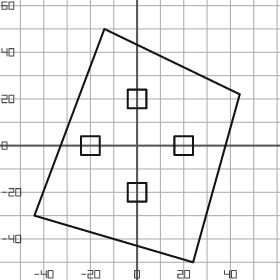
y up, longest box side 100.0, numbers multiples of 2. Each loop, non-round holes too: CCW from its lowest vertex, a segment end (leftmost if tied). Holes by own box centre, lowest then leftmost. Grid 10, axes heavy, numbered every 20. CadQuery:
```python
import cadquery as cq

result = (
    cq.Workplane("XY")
    .moveTo(24.0, -50.0)
    .lineTo(44.0, 22.0)
    .lineTo(-14.0, 50.0)
    .lineTo(-44.0, -30.0)
    .close()
    .moveTo(-4.0, -24.0)
    .lineTo(4.0, -24.0)
    .lineTo(4.0, -16.0)
    .lineTo(-4.0, -16.0)
    .close()
    .moveTo(-24.0, -4.0)
    .lineTo(-16.0, -4.0)
    .lineTo(-16.0, 4.0)
    .lineTo(-24.0, 4.0)
    .close()
    .moveTo(16.0, -4.0)
    .lineTo(24.0, -4.0)
    .lineTo(24.0, 4.0)
    .lineTo(16.0, 4.0)
    .close()
    .moveTo(-4.0, 16.0)
    .lineTo(4.0, 16.0)
    .lineTo(4.0, 24.0)
    .lineTo(-4.0, 24.0)
    .close()
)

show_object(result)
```